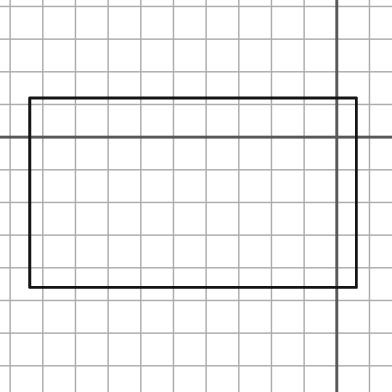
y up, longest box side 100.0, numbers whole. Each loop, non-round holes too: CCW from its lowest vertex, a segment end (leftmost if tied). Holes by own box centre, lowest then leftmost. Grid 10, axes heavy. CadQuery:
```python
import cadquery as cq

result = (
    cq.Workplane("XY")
    .moveTo(-94.0, -46.0)
    .lineTo(6.0, -46.0)
    .lineTo(6.0, 12.0)
    .lineTo(-94.0, 12.0)
    .close()
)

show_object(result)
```